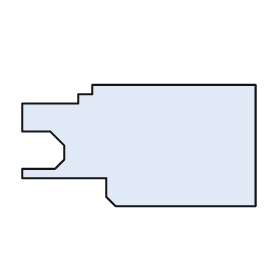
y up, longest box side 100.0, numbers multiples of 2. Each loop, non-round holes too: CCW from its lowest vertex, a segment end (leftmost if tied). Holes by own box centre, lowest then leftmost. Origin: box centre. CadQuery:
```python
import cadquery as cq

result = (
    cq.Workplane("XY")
    .moveTo(-10.0, -26.0)
    .lineTo(50.0, -26.0)
    .lineTo(50.0, 26.0)
    .lineTo(-20.0, 26.0)
    .lineTo(-20.0, 22.0)
    .lineTo(-26.0, 22.0)
    .lineTo(-26.0, 18.0)
    .lineTo(-50.0, 18.0)
    .lineTo(-50.0, 6.0)
    .lineTo(-38.0, 6.0)
    .lineTo(-32.0, 0.0)
    .lineTo(-32.0, -6.0)
    .lineTo(-36.0, -10.0)
    .lineTo(-50.0, -10.0)
    .lineTo(-50.0, -14.0)
    .lineTo(-14.0, -14.0)
    .lineTo(-14.0, -22.0)
    .close()
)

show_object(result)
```